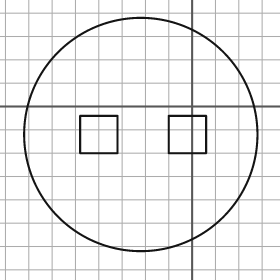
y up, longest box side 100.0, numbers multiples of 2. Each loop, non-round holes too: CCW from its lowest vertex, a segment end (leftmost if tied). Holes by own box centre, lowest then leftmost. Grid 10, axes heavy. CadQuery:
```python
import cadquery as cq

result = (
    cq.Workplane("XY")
    .moveTo(-22.0, -12.0)
    .circle(50.0)
    .moveTo(-48.0, -20.0)
    .lineTo(-32.0, -20.0)
    .lineTo(-32.0, -4.0)
    .lineTo(-48.0, -4.0)
    .close()
    .moveTo(-10.0, -20.0)
    .lineTo(6.0, -20.0)
    .lineTo(6.0, -4.0)
    .lineTo(-10.0, -4.0)
    .close()
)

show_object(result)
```